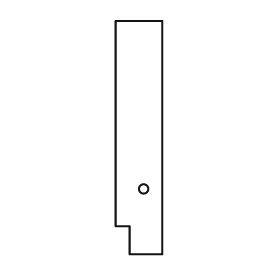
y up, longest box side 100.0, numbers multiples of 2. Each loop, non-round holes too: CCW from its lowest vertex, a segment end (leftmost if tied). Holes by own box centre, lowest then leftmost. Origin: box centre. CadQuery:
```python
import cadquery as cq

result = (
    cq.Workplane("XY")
    .moveTo(-4.0, -50.0)
    .lineTo(10.0, -50.0)
    .lineTo(10.0, 50.0)
    .lineTo(-10.0, 50.0)
    .lineTo(-10.0, -38.0)
    .lineTo(-4.0, -38.0)
    .close()
    .moveTo(2.0, -22.0)
    .circle(2.0)
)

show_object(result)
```